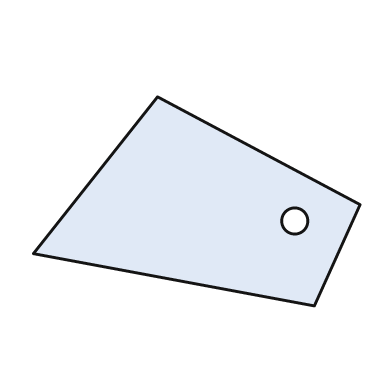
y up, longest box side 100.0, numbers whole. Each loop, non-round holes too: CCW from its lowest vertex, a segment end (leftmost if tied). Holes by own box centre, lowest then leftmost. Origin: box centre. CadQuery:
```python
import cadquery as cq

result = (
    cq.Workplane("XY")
    .moveTo(36.0, -32.0)
    .lineTo(50.0, -1.0)
    .lineTo(-12.0, 32.0)
    .lineTo(-50.0, -16.0)
    .close()
    .moveTo(30.0, -6.0)
    .circle(4.0)
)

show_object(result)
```